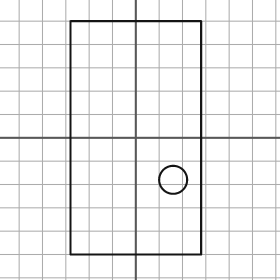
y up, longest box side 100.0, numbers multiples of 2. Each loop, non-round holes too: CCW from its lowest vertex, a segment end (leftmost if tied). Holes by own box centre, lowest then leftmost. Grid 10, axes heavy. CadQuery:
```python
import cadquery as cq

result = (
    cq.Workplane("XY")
    .moveTo(-28.0, -50.0)
    .lineTo(28.0, -50.0)
    .lineTo(28.0, 50.0)
    .lineTo(-28.0, 50.0)
    .close()
    .moveTo(16.0, -18.0)
    .circle(6.0)
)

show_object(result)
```